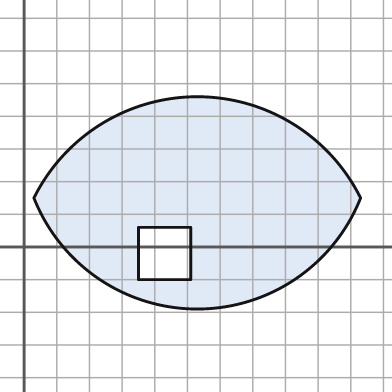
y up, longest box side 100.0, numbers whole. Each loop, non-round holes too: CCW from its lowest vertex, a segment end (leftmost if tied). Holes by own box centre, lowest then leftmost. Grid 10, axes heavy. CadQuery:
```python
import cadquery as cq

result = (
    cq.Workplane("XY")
    .moveTo(3.0, 15.0)
    .threePointArc((53.0, -19.0), (103.0, 15.0))
    .threePointArc((53.0, 46.0), (3.0, 15.0))
    .close()
    .moveTo(35.0, -10.0)
    .lineTo(51.0, -10.0)
    .lineTo(51.0, 6.0)
    .lineTo(35.0, 6.0)
    .close()
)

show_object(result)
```